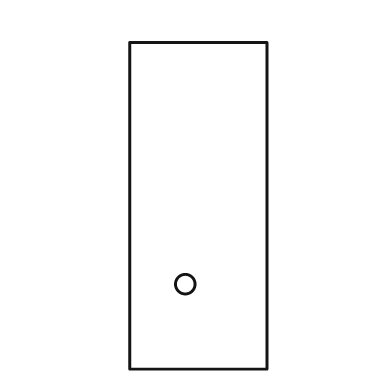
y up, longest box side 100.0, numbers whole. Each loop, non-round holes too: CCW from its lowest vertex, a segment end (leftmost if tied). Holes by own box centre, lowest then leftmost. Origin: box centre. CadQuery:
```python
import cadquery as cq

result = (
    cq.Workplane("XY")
    .moveTo(-21.0, -50.0)
    .lineTo(21.0, -50.0)
    .lineTo(21.0, 50.0)
    .lineTo(-21.0, 50.0)
    .close()
    .moveTo(-4.0, -24.0)
    .circle(3.0)
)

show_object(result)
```